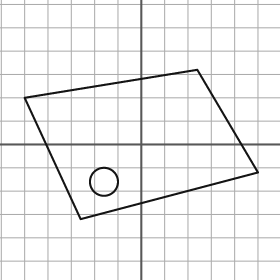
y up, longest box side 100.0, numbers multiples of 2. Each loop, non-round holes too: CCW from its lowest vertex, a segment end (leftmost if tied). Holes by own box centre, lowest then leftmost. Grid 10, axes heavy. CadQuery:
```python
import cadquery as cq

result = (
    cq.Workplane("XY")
    .moveTo(-26.0, -32.0)
    .lineTo(50.0, -12.0)
    .lineTo(24.0, 32.0)
    .lineTo(-50.0, 20.0)
    .close()
    .moveTo(-16.0, -16.0)
    .circle(6.0)
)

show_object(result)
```